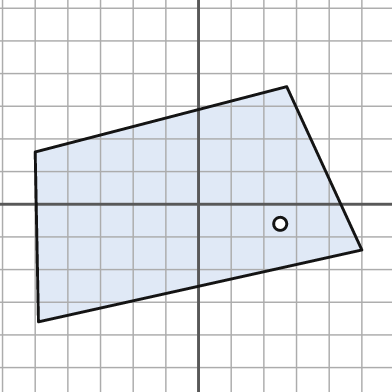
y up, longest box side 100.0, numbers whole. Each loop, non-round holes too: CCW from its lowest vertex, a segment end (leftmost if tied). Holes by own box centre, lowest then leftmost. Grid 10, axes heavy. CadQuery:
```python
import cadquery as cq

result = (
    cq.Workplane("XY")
    .moveTo(-49.0, -36.0)
    .lineTo(50.0, -14.0)
    .lineTo(27.0, 36.0)
    .lineTo(-50.0, 16.0)
    .close()
    .moveTo(25.0, -6.0)
    .circle(2.0)
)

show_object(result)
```